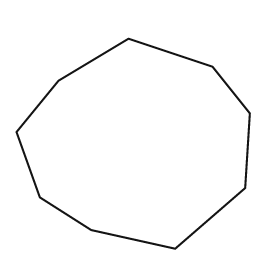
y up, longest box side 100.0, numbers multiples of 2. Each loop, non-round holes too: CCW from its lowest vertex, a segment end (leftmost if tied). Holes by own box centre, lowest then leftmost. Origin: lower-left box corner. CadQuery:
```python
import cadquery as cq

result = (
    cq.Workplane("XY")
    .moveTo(68.0, 0.0)
    .lineTo(98.0, 26.0)
    .lineTo(100.0, 58.0)
    .lineTo(84.0, 78.0)
    .lineTo(48.0, 90.0)
    .lineTo(18.0, 72.0)
    .lineTo(0.0, 50.0)
    .lineTo(10.0, 22.0)
    .lineTo(32.0, 8.0)
    .close()
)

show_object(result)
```